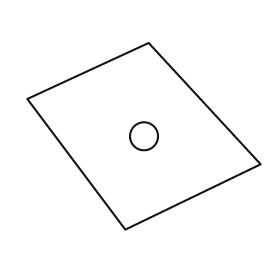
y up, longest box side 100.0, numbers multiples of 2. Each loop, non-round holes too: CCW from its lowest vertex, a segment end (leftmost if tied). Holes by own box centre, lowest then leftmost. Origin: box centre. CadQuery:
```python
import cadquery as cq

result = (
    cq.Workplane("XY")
    .moveTo(-8.0, -40.0)
    .lineTo(50.0, -12.0)
    .lineTo(2.0, 40.0)
    .lineTo(-50.0, 16.0)
    .close()
    .moveTo(0.0, 0.0)
    .circle(6.0)
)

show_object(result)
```